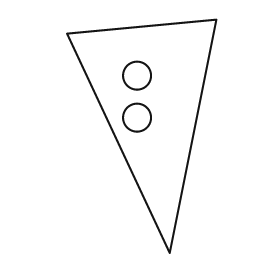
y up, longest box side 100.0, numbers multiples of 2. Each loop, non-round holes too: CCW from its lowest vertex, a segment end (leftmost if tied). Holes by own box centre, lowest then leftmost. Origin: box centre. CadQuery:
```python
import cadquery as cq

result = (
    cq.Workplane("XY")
    .moveTo(12.0, -50.0)
    .lineTo(32.0, 50.0)
    .lineTo(-32.0, 44.0)
    .close()
    .moveTo(-2.0, 8.0)
    .circle(6.0)
    .moveTo(-2.0, 26.0)
    .circle(6.0)
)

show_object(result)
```